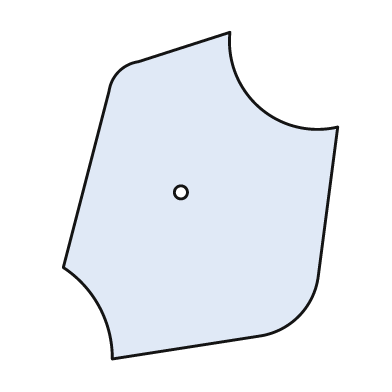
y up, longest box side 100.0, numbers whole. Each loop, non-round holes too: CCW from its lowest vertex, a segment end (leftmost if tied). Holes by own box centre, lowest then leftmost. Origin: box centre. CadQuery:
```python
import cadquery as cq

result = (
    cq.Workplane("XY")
    .moveTo(-27.0, -50.0)
    .lineTo(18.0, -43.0)
    .threePointArc((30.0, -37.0), (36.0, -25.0))
    .lineTo(42.0, 21.0)
    .threePointArc((18.0, 27.0), (9.0, 50.0))
    .lineTo(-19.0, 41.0)
    .threePointArc((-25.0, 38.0), (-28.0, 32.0))
    .lineTo(-42.0, -22.0)
    .threePointArc((-31.0, -34.0), (-27.0, -50.0))
    .close()
    .moveTo(-6.0, 1.0)
    .circle(2.0)
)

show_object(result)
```